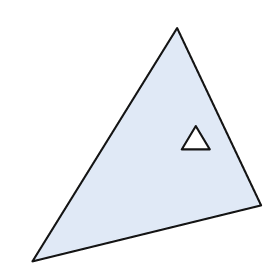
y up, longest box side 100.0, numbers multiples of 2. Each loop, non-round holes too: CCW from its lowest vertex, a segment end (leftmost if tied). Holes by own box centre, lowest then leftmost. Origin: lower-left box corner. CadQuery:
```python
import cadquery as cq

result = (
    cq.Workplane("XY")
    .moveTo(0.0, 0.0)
    .lineTo(98.0, 24.0)
    .lineTo(62.0, 100.0)
    .close()
    .moveTo(64.0, 48.0)
    .lineTo(76.0, 48.0)
    .lineTo(70.0, 58.0)
    .close()
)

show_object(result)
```